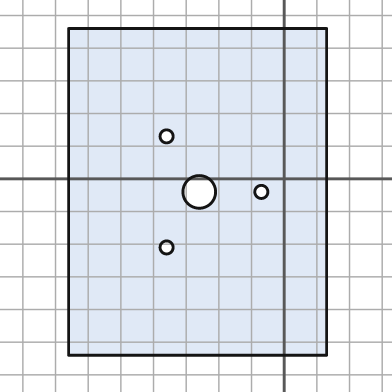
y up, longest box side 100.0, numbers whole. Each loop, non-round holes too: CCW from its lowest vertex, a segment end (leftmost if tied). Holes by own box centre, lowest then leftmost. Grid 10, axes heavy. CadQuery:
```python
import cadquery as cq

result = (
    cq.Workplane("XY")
    .moveTo(-66.0, -54.0)
    .lineTo(13.0, -54.0)
    .lineTo(13.0, 46.0)
    .lineTo(-66.0, 46.0)
    .close()
    .moveTo(-36.0, -21.0)
    .circle(2.0)
    .moveTo(-26.0, -4.0)
    .circle(5.0)
    .moveTo(-7.0, -4.0)
    .circle(2.0)
    .moveTo(-36.0, 13.0)
    .circle(2.0)
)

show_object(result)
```